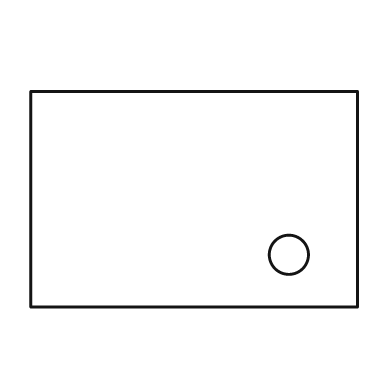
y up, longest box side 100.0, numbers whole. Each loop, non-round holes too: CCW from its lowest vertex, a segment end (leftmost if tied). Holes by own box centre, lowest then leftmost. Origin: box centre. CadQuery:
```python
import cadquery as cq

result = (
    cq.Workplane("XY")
    .moveTo(-50.0, -33.0)
    .lineTo(50.0, -33.0)
    .lineTo(50.0, 33.0)
    .lineTo(-50.0, 33.0)
    .close()
    .moveTo(29.0, -17.0)
    .circle(6.0)
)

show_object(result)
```